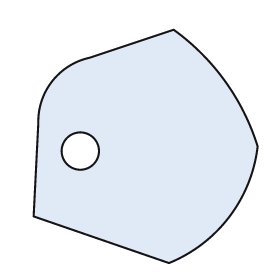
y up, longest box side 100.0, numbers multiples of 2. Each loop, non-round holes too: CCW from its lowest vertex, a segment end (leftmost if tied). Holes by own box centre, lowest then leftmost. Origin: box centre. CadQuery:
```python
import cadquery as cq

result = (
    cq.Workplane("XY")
    .moveTo(10.0, -50.0)
    .threePointArc((36.0, -30.0), (48.0, 0.0))
    .threePointArc((34.0, 28.0), (12.0, 50.0))
    .lineTo(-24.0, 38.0)
    .threePointArc((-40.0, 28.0), (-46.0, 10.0))
    .lineTo(-48.0, -30.0)
    .close()
    .moveTo(-28.0, -2.0)
    .circle(8.0)
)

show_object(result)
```